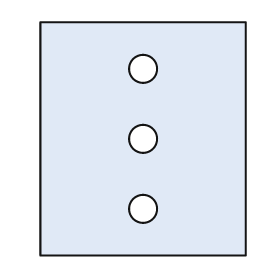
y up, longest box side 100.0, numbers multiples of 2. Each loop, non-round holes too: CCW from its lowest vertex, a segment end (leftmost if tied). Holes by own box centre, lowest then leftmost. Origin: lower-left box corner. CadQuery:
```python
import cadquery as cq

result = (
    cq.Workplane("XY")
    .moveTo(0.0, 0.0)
    .lineTo(88.0, 0.0)
    .lineTo(88.0, 100.0)
    .lineTo(0.0, 100.0)
    .close()
    .moveTo(44.0, 20.0)
    .circle(6.0)
    .moveTo(44.0, 50.0)
    .circle(6.0)
    .moveTo(44.0, 80.0)
    .circle(6.0)
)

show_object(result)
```